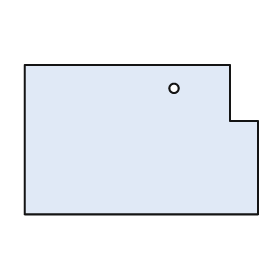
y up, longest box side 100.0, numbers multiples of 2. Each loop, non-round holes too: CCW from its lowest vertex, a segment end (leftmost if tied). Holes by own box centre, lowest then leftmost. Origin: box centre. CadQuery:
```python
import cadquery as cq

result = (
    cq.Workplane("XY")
    .moveTo(-50.0, -32.0)
    .lineTo(50.0, -32.0)
    .lineTo(50.0, 8.0)
    .lineTo(38.0, 8.0)
    .lineTo(38.0, 32.0)
    .lineTo(-50.0, 32.0)
    .close()
    .moveTo(14.0, 22.0)
    .circle(2.0)
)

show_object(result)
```